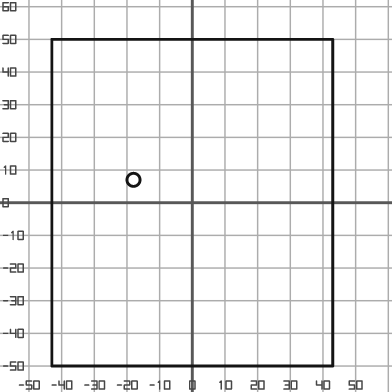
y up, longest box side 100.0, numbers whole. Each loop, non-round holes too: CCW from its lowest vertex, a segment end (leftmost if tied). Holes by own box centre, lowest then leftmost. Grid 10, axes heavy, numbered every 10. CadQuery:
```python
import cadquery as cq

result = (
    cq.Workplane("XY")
    .moveTo(-43.0, -50.0)
    .lineTo(43.0, -50.0)
    .lineTo(43.0, 50.0)
    .lineTo(-43.0, 50.0)
    .close()
    .moveTo(-18.0, 7.0)
    .circle(2.0)
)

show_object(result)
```